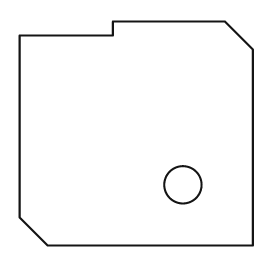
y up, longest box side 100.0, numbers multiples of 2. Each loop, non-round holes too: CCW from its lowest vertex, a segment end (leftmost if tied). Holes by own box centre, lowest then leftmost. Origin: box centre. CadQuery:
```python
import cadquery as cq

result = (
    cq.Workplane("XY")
    .moveTo(-38.0, -48.0)
    .lineTo(50.0, -48.0)
    .lineTo(50.0, 36.0)
    .lineTo(38.0, 48.0)
    .lineTo(-10.0, 48.0)
    .lineTo(-10.0, 42.0)
    .lineTo(-50.0, 42.0)
    .lineTo(-50.0, -36.0)
    .close()
    .moveTo(20.0, -22.0)
    .circle(8.0)
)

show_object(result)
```